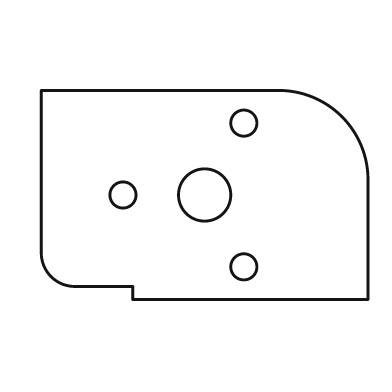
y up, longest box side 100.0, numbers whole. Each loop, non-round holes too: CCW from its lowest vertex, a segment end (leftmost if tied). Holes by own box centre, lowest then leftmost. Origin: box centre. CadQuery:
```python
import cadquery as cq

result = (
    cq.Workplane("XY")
    .moveTo(-22.0, -32.0)
    .lineTo(50.0, -32.0)
    .lineTo(50.0, 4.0)
    .threePointArc((42.0, 24.0), (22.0, 32.0))
    .lineTo(-50.0, 32.0)
    .lineTo(-50.0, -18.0)
    .threePointArc((-47.0, -25.0), (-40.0, -28.0))
    .lineTo(-22.0, -28.0)
    .close()
    .moveTo(12.0, -22.0)
    .circle(4.0)
    .moveTo(-25.0, 0.0)
    .circle(4.0)
    .moveTo(0.0, 0.0)
    .circle(8.0)
    .moveTo(12.0, 22.0)
    .circle(4.0)
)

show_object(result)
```